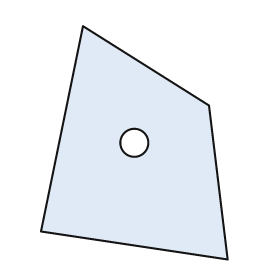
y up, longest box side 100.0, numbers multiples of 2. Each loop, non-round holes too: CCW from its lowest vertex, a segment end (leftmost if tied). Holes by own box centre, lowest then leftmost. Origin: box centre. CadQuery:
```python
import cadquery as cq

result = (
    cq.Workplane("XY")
    .moveTo(40.0, -50.0)
    .lineTo(32.0, 16.0)
    .lineTo(-22.0, 50.0)
    .lineTo(-40.0, -38.0)
    .close()
    .moveTo(0.0, 0.0)
    .circle(6.0)
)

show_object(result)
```